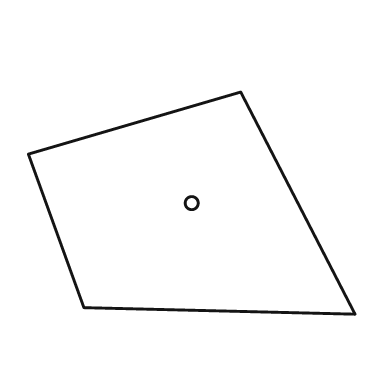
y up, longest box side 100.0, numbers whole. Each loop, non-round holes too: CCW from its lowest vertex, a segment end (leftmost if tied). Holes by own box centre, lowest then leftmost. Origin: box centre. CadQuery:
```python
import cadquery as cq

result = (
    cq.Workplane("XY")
    .moveTo(50.0, -34.0)
    .lineTo(15.0, 34.0)
    .lineTo(-50.0, 15.0)
    .lineTo(-33.0, -32.0)
    .close()
    .moveTo(0.0, 0.0)
    .circle(2.0)
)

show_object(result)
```